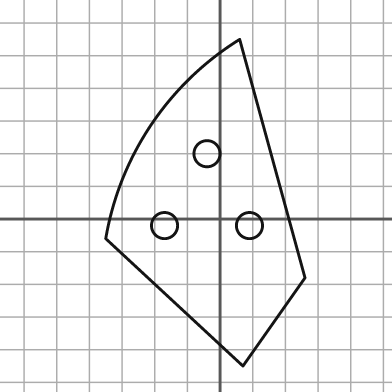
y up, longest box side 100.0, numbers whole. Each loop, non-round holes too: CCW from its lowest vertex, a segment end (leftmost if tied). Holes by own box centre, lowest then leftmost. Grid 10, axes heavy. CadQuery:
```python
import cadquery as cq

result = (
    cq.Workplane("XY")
    .moveTo(7.0, -45.0)
    .lineTo(26.0, -18.0)
    .lineTo(6.0, 55.0)
    .threePointArc((-21.0, 29.0), (-35.0, -6.0))
    .close()
    .moveTo(-17.0, -2.0)
    .circle(4.0)
    .moveTo(9.0, -2.0)
    .circle(4.0)
    .moveTo(-4.0, 20.0)
    .circle(4.0)
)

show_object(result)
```